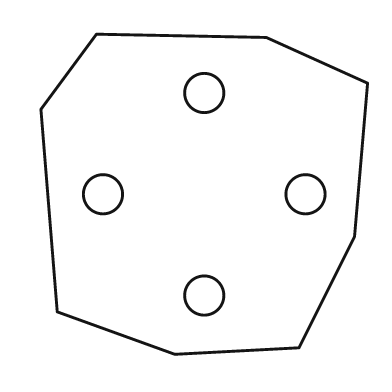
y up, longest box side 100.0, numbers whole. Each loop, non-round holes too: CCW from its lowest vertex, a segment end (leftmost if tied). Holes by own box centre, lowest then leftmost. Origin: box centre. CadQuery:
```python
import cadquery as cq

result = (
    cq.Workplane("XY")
    .moveTo(-9.0, -49.0)
    .lineTo(29.0, -47.0)
    .lineTo(46.0, -13.0)
    .lineTo(50.0, 34.0)
    .lineTo(19.0, 48.0)
    .lineTo(-33.0, 49.0)
    .lineTo(-50.0, 26.0)
    .lineTo(-45.0, -36.0)
    .close()
    .moveTo(0.0, -31.0)
    .circle(6.0)
    .moveTo(-31.0, 0.0)
    .circle(6.0)
    .moveTo(31.0, 0.0)
    .circle(6.0)
    .moveTo(0.0, 31.0)
    .circle(6.0)
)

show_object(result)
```